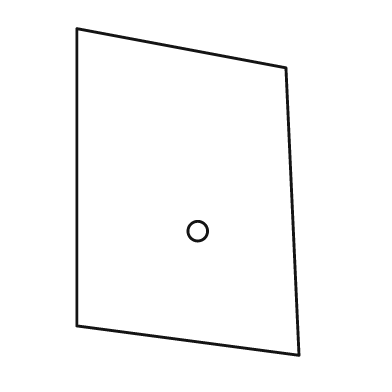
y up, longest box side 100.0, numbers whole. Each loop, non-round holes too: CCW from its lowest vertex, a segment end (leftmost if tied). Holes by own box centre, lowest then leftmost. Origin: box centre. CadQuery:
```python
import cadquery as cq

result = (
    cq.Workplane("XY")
    .moveTo(34.0, -50.0)
    .lineTo(30.0, 38.0)
    .lineTo(-34.0, 50.0)
    .lineTo(-34.0, -41.0)
    .close()
    .moveTo(3.0, -12.0)
    .circle(3.0)
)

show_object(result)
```